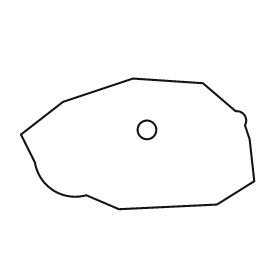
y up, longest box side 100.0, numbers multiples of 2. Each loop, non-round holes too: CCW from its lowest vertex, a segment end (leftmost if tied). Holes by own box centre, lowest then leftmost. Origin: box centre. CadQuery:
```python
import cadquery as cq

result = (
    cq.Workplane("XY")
    .moveTo(-8.0, -28.0)
    .lineTo(34.0, -26.0)
    .lineTo(50.0, -16.0)
    .lineTo(48.0, 2.0)
    .lineTo(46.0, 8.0)
    .threePointArc((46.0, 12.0), (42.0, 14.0))
    .lineTo(28.0, 26.0)
    .lineTo(-2.0, 28.0)
    .lineTo(-32.0, 18.0)
    .lineTo(-50.0, 4.0)
    .lineTo(-44.0, -8.0)
    .threePointArc((-36.0, -20.0), (-22.0, -22.0))
    .close()
    .moveTo(4.0, 6.0)
    .circle(4.0)
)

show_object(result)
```